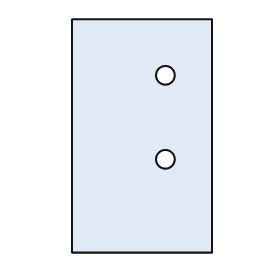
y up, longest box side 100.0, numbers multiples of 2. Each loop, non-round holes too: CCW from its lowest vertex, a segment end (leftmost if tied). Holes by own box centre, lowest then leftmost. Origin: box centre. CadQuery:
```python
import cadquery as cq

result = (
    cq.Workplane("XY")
    .moveTo(-30.0, -50.0)
    .lineTo(30.0, -50.0)
    .lineTo(30.0, 50.0)
    .lineTo(-30.0, 50.0)
    .close()
    .moveTo(10.0, -10.0)
    .circle(4.0)
    .moveTo(10.0, 26.0)
    .circle(4.0)
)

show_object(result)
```